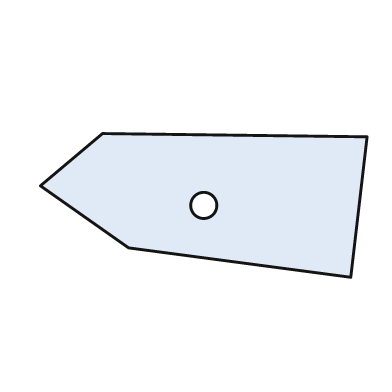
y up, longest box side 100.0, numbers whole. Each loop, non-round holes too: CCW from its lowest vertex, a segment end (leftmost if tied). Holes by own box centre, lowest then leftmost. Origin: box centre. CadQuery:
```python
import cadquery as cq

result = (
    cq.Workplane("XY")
    .moveTo(45.0, -22.0)
    .lineTo(50.0, 21.0)
    .lineTo(-31.0, 22.0)
    .lineTo(-50.0, 6.0)
    .lineTo(-23.0, -13.0)
    .close()
    .moveTo(0.0, 0.0)
    .circle(4.0)
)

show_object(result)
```